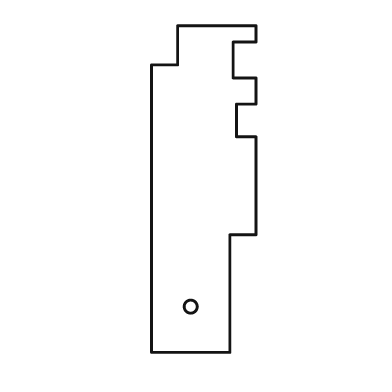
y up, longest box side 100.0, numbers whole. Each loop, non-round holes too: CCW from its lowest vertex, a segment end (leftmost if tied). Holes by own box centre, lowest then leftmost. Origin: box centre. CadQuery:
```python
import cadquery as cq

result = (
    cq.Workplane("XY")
    .moveTo(-16.0, -50.0)
    .lineTo(8.0, -50.0)
    .lineTo(8.0, -14.0)
    .lineTo(16.0, -14.0)
    .lineTo(16.0, 16.0)
    .lineTo(10.0, 16.0)
    .lineTo(10.0, 26.0)
    .lineTo(16.0, 26.0)
    .lineTo(16.0, 34.0)
    .lineTo(9.0, 34.0)
    .lineTo(9.0, 45.0)
    .lineTo(16.0, 45.0)
    .lineTo(16.0, 50.0)
    .lineTo(-8.0, 50.0)
    .lineTo(-8.0, 38.0)
    .lineTo(-16.0, 38.0)
    .close()
    .moveTo(-4.0, -36.0)
    .circle(2.0)
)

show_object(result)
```